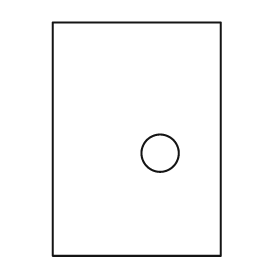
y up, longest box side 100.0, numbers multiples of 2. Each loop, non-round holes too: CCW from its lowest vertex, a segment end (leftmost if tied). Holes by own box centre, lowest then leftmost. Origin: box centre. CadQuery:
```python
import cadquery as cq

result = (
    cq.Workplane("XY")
    .moveTo(-36.0, -50.0)
    .lineTo(36.0, -50.0)
    .lineTo(36.0, 50.0)
    .lineTo(-36.0, 50.0)
    .close()
    .moveTo(10.0, -6.0)
    .circle(8.0)
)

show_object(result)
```